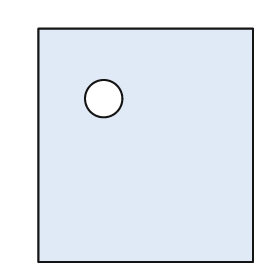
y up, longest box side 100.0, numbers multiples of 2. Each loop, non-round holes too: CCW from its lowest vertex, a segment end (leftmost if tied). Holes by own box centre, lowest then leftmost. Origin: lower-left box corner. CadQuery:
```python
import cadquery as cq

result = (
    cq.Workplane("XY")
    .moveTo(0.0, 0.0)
    .lineTo(92.0, 0.0)
    .lineTo(92.0, 100.0)
    .lineTo(0.0, 100.0)
    .close()
    .moveTo(28.0, 70.0)
    .circle(8.0)
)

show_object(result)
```